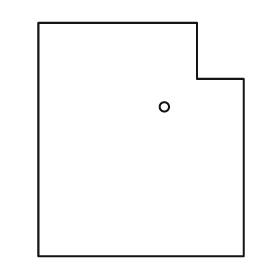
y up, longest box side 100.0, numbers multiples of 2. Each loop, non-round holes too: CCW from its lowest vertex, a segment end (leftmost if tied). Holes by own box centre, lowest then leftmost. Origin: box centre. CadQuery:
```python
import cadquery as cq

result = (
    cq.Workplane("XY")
    .moveTo(-44.0, -50.0)
    .lineTo(44.0, -50.0)
    .lineTo(44.0, 26.0)
    .lineTo(24.0, 26.0)
    .lineTo(24.0, 50.0)
    .lineTo(-44.0, 50.0)
    .close()
    .moveTo(10.0, 14.0)
    .circle(2.0)
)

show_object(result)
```